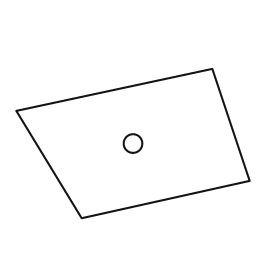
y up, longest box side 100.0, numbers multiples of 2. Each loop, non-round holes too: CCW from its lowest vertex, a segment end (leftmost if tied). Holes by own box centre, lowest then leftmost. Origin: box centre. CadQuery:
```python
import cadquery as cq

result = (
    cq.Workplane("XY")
    .moveTo(-22.0, -32.0)
    .lineTo(50.0, -16.0)
    .lineTo(34.0, 32.0)
    .lineTo(-50.0, 14.0)
    .close()
    .moveTo(0.0, 0.0)
    .circle(4.0)
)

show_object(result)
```